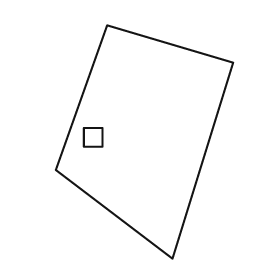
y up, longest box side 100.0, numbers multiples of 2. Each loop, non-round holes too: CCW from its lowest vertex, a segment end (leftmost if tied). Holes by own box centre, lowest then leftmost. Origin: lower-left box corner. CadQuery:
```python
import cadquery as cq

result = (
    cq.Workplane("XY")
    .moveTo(50.0, 0.0)
    .lineTo(76.0, 84.0)
    .lineTo(22.0, 100.0)
    .lineTo(0.0, 38.0)
    .close()
    .moveTo(12.0, 48.0)
    .lineTo(20.0, 48.0)
    .lineTo(20.0, 56.0)
    .lineTo(12.0, 56.0)
    .close()
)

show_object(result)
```